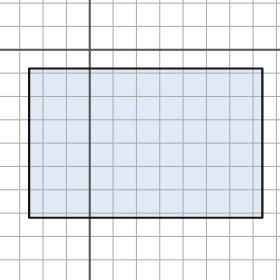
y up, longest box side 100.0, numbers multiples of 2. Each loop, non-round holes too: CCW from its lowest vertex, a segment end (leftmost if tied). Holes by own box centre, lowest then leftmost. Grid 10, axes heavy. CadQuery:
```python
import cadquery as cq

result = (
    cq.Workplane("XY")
    .moveTo(-26.0, -72.0)
    .lineTo(74.0, -72.0)
    .lineTo(74.0, -8.0)
    .lineTo(-26.0, -8.0)
    .close()
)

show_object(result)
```